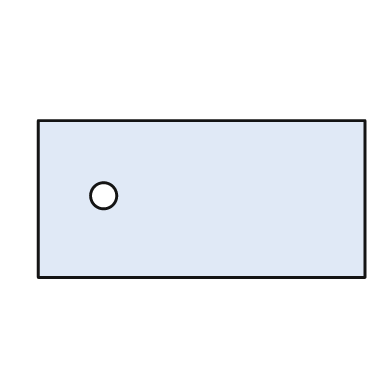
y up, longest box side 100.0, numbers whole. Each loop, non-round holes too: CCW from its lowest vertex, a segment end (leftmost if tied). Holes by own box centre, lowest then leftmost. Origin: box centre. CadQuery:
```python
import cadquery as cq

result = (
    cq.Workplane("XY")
    .moveTo(-50.0, -24.0)
    .lineTo(50.0, -24.0)
    .lineTo(50.0, 24.0)
    .lineTo(-50.0, 24.0)
    .close()
    .moveTo(-30.0, 1.0)
    .circle(4.0)
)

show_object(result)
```